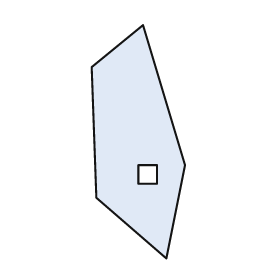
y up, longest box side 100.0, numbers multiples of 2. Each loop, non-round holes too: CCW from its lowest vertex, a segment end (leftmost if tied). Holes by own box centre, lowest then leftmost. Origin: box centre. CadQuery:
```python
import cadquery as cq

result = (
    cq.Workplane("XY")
    .moveTo(12.0, -50.0)
    .lineTo(20.0, -10.0)
    .lineTo(2.0, 50.0)
    .lineTo(-20.0, 32.0)
    .lineTo(-18.0, -24.0)
    .close()
    .moveTo(0.0, -18.0)
    .lineTo(8.0, -18.0)
    .lineTo(8.0, -10.0)
    .lineTo(0.0, -10.0)
    .close()
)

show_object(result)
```